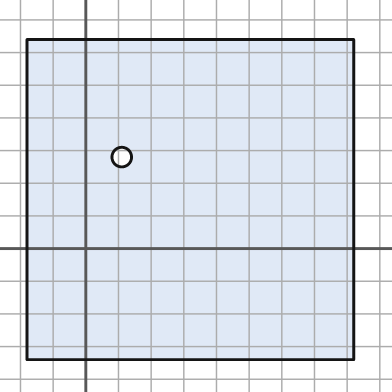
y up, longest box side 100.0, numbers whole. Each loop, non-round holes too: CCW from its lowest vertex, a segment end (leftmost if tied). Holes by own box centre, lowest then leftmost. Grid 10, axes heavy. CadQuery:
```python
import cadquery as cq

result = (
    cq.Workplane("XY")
    .moveTo(-18.0, -34.0)
    .lineTo(82.0, -34.0)
    .lineTo(82.0, 64.0)
    .lineTo(-18.0, 64.0)
    .close()
    .moveTo(11.0, 28.0)
    .circle(3.0)
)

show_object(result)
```